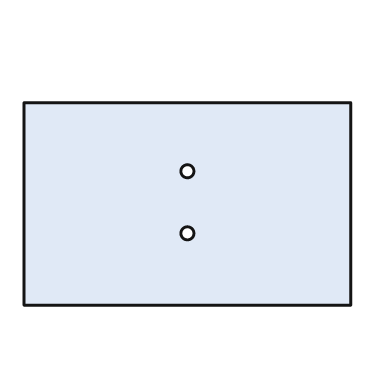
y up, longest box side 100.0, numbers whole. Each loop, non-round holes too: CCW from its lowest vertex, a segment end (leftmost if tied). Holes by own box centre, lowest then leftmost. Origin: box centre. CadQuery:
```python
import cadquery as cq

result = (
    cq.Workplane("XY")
    .moveTo(-50.0, -31.0)
    .lineTo(50.0, -31.0)
    .lineTo(50.0, 31.0)
    .lineTo(-50.0, 31.0)
    .close()
    .moveTo(0.0, -9.0)
    .circle(2.0)
    .moveTo(0.0, 10.0)
    .circle(2.0)
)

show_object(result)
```